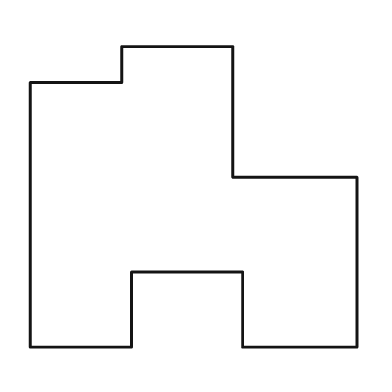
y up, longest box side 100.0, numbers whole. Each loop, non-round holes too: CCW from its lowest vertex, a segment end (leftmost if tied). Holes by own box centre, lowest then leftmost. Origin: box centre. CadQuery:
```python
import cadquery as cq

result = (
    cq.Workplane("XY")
    .moveTo(-50.0, -46.0)
    .lineTo(-19.0, -46.0)
    .lineTo(-19.0, -23.0)
    .lineTo(15.0, -23.0)
    .lineTo(15.0, -46.0)
    .lineTo(50.0, -46.0)
    .lineTo(50.0, 6.0)
    .lineTo(12.0, 6.0)
    .lineTo(12.0, 46.0)
    .lineTo(-22.0, 46.0)
    .lineTo(-22.0, 35.0)
    .lineTo(-50.0, 35.0)
    .close()
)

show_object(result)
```